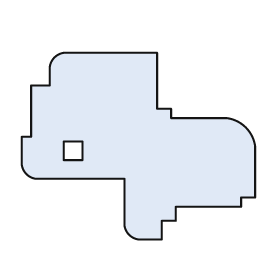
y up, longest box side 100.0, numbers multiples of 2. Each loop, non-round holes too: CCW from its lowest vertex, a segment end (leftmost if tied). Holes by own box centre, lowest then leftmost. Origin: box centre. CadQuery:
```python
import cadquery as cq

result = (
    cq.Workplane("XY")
    .moveTo(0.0, -40.0)
    .lineTo(10.0, -40.0)
    .lineTo(10.0, -32.0)
    .lineTo(16.0, -32.0)
    .lineTo(16.0, -26.0)
    .lineTo(44.0, -26.0)
    .lineTo(44.0, -22.0)
    .lineTo(50.0, -22.0)
    .lineTo(50.0, 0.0)
    .threePointArc((46.0, 8.0), (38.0, 12.0))
    .lineTo(14.0, 12.0)
    .lineTo(14.0, 16.0)
    .lineTo(8.0, 16.0)
    .lineTo(8.0, 40.0)
    .lineTo(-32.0, 40.0)
    .threePointArc((-36.0, 38.0), (-38.0, 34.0))
    .lineTo(-38.0, 26.0)
    .lineTo(-46.0, 26.0)
    .lineTo(-46.0, 4.0)
    .lineTo(-50.0, 4.0)
    .lineTo(-50.0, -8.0)
    .threePointArc((-48.0, -12.0), (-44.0, -14.0))
    .lineTo(-6.0, -14.0)
    .lineTo(-6.0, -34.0)
    .threePointArc((-4.0, -38.0), (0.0, -40.0))
    .close()
    .moveTo(-32.0, -6.0)
    .lineTo(-24.0, -6.0)
    .lineTo(-24.0, 2.0)
    .lineTo(-32.0, 2.0)
    .close()
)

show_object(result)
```